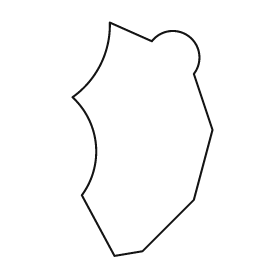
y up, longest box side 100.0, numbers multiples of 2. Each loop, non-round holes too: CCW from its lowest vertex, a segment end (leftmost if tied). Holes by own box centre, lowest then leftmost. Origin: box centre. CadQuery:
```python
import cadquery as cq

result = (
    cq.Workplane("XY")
    .moveTo(-12.0, -50.0)
    .lineTo(0.0, -48.0)
    .lineTo(22.0, -26.0)
    .lineTo(30.0, 4.0)
    .lineTo(22.0, 28.0)
    .threePointArc((20.0, 44.0), (4.0, 42.0))
    .lineTo(-14.0, 50.0)
    .threePointArc((-18.0, 32.0), (-30.0, 18.0))
    .threePointArc((-20.0, -2.0), (-26.0, -24.0))
    .close()
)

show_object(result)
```